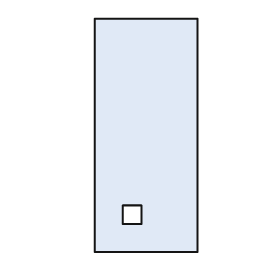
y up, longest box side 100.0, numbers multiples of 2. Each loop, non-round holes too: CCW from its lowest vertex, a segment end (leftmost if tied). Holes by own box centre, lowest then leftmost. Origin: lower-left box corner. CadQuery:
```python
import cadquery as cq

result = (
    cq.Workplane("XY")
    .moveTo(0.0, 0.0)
    .lineTo(44.0, 0.0)
    .lineTo(44.0, 100.0)
    .lineTo(0.0, 100.0)
    .close()
    .moveTo(12.0, 12.0)
    .lineTo(20.0, 12.0)
    .lineTo(20.0, 20.0)
    .lineTo(12.0, 20.0)
    .close()
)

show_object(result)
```